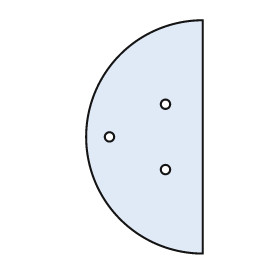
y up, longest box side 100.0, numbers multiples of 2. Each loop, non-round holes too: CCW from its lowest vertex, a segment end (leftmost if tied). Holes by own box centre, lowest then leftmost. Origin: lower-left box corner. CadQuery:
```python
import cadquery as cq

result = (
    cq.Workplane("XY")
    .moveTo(50.0, 0.0)
    .lineTo(50.0, 100.0)
    .threePointArc((0.0, 50.0), (50.0, 0.0))
    .close()
    .moveTo(34.0, 36.0)
    .circle(2.0)
    .moveTo(10.0, 50.0)
    .circle(2.0)
    .moveTo(34.0, 64.0)
    .circle(2.0)
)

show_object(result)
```